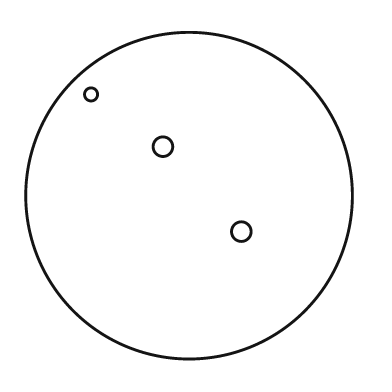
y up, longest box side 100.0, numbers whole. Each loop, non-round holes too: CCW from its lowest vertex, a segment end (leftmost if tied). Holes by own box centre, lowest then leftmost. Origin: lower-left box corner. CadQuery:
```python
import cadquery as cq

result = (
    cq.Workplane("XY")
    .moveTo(50.0, 50.0)
    .circle(50.0)
    .moveTo(66.0, 39.0)
    .circle(3.0)
    .moveTo(42.0, 65.0)
    .circle(3.0)
    .moveTo(20.0, 81.0)
    .circle(2.0)
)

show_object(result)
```